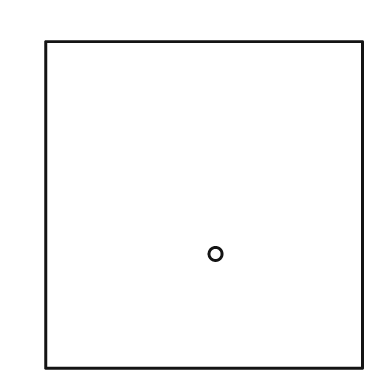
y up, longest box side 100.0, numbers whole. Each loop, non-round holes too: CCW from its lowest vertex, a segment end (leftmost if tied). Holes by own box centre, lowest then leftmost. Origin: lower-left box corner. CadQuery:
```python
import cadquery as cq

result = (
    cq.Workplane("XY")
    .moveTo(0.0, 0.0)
    .lineTo(97.0, 0.0)
    .lineTo(97.0, 100.0)
    .lineTo(0.0, 100.0)
    .close()
    .moveTo(52.0, 35.0)
    .circle(2.0)
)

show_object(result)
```